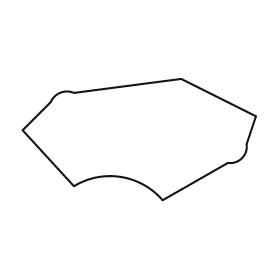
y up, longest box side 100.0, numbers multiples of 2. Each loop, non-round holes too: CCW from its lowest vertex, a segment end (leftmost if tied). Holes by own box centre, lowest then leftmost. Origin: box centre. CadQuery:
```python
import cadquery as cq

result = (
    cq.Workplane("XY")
    .moveTo(10.0, -26.0)
    .lineTo(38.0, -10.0)
    .threePointArc((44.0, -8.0), (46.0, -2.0))
    .lineTo(50.0, 10.0)
    .lineTo(18.0, 26.0)
    .lineTo(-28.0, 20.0)
    .threePointArc((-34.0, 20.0), (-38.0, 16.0))
    .lineTo(-50.0, 4.0)
    .lineTo(-28.0, -20.0)
    .threePointArc((-8.0, -16.0), (10.0, -26.0))
    .close()
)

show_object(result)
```